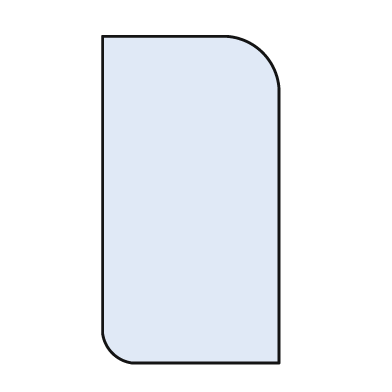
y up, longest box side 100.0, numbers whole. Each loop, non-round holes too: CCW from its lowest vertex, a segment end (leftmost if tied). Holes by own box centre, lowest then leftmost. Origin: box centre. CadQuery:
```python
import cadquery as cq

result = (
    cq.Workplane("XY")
    .moveTo(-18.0, -50.0)
    .lineTo(27.0, -50.0)
    .lineTo(27.0, 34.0)
    .threePointArc((22.0, 45.0), (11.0, 50.0))
    .lineTo(-27.0, 50.0)
    .lineTo(-27.0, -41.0)
    .threePointArc((-24.0, -47.0), (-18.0, -50.0))
    .close()
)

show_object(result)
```